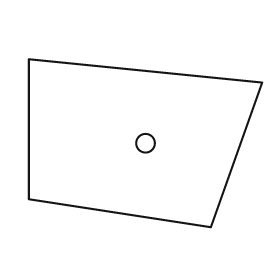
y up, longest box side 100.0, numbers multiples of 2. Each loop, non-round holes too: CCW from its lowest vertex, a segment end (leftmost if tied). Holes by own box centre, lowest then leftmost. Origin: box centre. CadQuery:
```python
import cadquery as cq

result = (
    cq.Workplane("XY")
    .moveTo(28.0, -36.0)
    .lineTo(50.0, 26.0)
    .lineTo(-50.0, 36.0)
    .lineTo(-50.0, -24.0)
    .close()
    .moveTo(0.0, 0.0)
    .circle(4.0)
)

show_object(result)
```